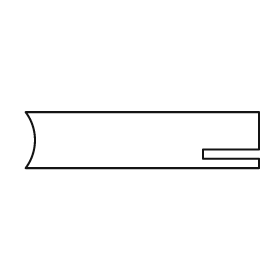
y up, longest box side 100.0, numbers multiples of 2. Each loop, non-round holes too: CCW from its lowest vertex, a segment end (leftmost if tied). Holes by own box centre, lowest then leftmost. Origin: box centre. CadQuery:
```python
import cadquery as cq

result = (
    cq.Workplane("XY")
    .moveTo(-50.0, -12.0)
    .lineTo(50.0, -12.0)
    .lineTo(50.0, -8.0)
    .lineTo(26.0, -8.0)
    .lineTo(26.0, -4.0)
    .lineTo(50.0, -4.0)
    .lineTo(50.0, 12.0)
    .lineTo(-50.0, 12.0)
    .threePointArc((-46.0, 0.0), (-50.0, -12.0))
    .close()
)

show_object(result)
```